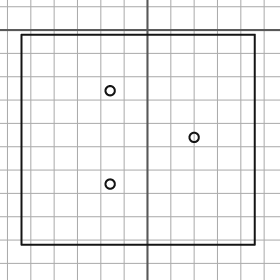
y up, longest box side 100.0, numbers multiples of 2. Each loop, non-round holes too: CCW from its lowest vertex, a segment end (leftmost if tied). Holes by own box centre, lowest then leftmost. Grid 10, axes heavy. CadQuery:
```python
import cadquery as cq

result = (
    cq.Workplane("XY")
    .moveTo(-54.0, -92.0)
    .lineTo(46.0, -92.0)
    .lineTo(46.0, -2.0)
    .lineTo(-54.0, -2.0)
    .close()
    .moveTo(-16.0, -66.0)
    .circle(2.0)
    .moveTo(20.0, -46.0)
    .circle(2.0)
    .moveTo(-16.0, -26.0)
    .circle(2.0)
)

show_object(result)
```